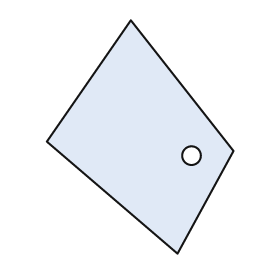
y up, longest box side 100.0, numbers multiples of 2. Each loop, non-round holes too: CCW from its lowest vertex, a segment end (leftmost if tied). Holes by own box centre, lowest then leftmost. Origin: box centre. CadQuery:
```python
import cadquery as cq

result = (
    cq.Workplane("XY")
    .moveTo(16.0, -50.0)
    .lineTo(40.0, -6.0)
    .lineTo(-4.0, 50.0)
    .lineTo(-40.0, -2.0)
    .close()
    .moveTo(22.0, -8.0)
    .circle(4.0)
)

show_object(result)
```